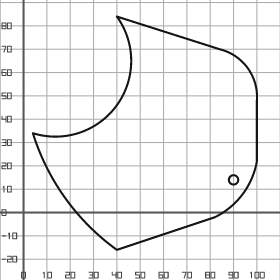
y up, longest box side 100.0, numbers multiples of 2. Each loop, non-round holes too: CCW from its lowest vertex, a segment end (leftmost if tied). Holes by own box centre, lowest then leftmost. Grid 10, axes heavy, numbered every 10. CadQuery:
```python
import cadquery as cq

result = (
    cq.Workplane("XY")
    .moveTo(40.0, -16.0)
    .lineTo(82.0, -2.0)
    .threePointArc((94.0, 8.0), (100.0, 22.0))
    .lineTo(100.0, 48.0)
    .threePointArc((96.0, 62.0), (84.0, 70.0))
    .lineTo(40.0, 84.0)
    .threePointArc((40.0, 46.0), (4.0, 34.0))
    .threePointArc((18.0, 6.0), (40.0, -16.0))
    .close()
    .moveTo(90.0, 14.0)
    .circle(2.0)
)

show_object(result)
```